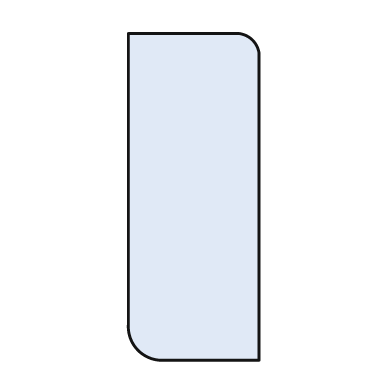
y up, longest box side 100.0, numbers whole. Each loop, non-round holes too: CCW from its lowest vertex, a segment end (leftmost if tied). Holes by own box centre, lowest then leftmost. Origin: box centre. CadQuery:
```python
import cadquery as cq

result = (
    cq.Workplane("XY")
    .moveTo(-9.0, -50.0)
    .lineTo(20.0, -50.0)
    .lineTo(20.0, 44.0)
    .threePointArc((18.0, 48.0), (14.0, 50.0))
    .lineTo(-20.0, 50.0)
    .lineTo(-20.0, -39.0)
    .threePointArc((-17.0, -47.0), (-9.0, -50.0))
    .close()
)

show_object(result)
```